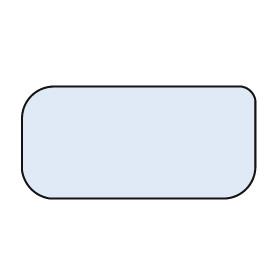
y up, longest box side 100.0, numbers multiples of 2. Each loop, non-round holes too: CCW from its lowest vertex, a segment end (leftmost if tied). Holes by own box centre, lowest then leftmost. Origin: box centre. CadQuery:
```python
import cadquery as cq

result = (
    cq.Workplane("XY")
    .moveTo(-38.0, -24.0)
    .lineTo(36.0, -24.0)
    .threePointArc((46.0, -20.0), (50.0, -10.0))
    .lineTo(50.0, 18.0)
    .threePointArc((48.0, 22.0), (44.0, 24.0))
    .lineTo(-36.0, 24.0)
    .threePointArc((-46.0, 20.0), (-50.0, 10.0))
    .lineTo(-50.0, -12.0)
    .threePointArc((-46.0, -20.0), (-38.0, -24.0))
    .close()
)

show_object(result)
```